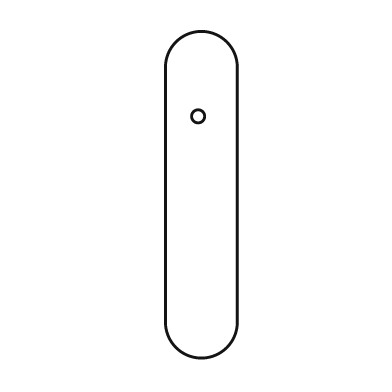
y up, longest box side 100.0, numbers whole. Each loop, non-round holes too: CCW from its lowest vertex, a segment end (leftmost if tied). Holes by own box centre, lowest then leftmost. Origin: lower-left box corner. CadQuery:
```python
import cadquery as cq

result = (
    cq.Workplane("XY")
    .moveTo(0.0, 11.0)
    .threePointArc((11.0, 0.0), (22.0, 11.0))
    .lineTo(22.0, 89.0)
    .threePointArc((11.0, 100.0), (0.0, 89.0))
    .close()
    .moveTo(10.0, 74.0)
    .circle(2.0)
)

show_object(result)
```